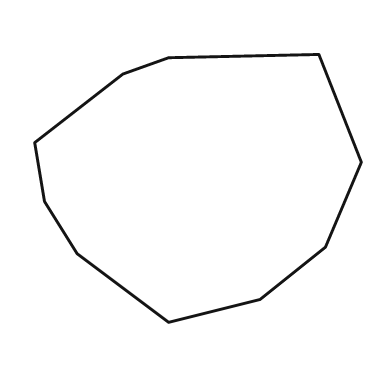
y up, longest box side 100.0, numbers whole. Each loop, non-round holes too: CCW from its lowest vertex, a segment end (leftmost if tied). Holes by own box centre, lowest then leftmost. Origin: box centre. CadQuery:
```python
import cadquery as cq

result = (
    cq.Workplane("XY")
    .moveTo(-9.0, -41.0)
    .lineTo(19.0, -34.0)
    .lineTo(39.0, -18.0)
    .lineTo(50.0, 8.0)
    .lineTo(37.0, 41.0)
    .lineTo(-9.0, 40.0)
    .lineTo(-23.0, 35.0)
    .lineTo(-50.0, 14.0)
    .lineTo(-47.0, -4.0)
    .lineTo(-37.0, -20.0)
    .close()
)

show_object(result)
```